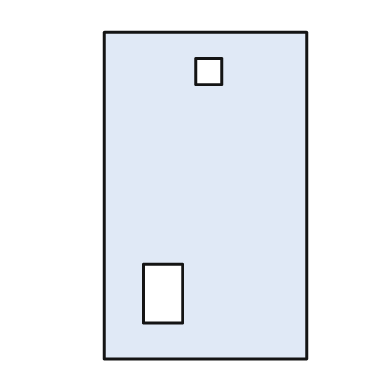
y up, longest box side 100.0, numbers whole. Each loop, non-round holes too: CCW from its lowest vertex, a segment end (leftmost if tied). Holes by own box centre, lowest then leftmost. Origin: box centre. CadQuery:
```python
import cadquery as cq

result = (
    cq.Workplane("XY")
    .moveTo(-31.0, -50.0)
    .lineTo(31.0, -50.0)
    .lineTo(31.0, 50.0)
    .lineTo(-31.0, 50.0)
    .close()
    .moveTo(-19.0, -39.0)
    .lineTo(-7.0, -39.0)
    .lineTo(-7.0, -21.0)
    .lineTo(-19.0, -21.0)
    .close()
    .moveTo(-3.0, 34.0)
    .lineTo(5.0, 34.0)
    .lineTo(5.0, 42.0)
    .lineTo(-3.0, 42.0)
    .close()
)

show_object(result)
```